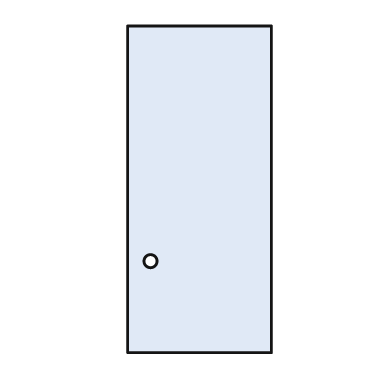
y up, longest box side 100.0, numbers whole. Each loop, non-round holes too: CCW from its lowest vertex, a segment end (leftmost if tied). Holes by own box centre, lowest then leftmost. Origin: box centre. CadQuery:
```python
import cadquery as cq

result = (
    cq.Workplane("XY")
    .moveTo(-22.0, -50.0)
    .lineTo(22.0, -50.0)
    .lineTo(22.0, 50.0)
    .lineTo(-22.0, 50.0)
    .close()
    .moveTo(-15.0, -22.0)
    .circle(2.0)
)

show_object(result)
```